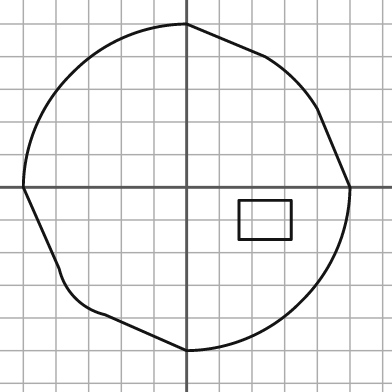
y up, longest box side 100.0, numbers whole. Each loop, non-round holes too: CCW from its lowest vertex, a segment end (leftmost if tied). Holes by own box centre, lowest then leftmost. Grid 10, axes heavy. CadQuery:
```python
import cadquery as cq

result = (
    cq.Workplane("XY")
    .moveTo(0.0, -50.0)
    .threePointArc((19.0, -46.0), (35.0, -35.0))
    .threePointArc((46.0, -19.0), (50.0, 0.0))
    .lineTo(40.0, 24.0)
    .threePointArc((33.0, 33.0), (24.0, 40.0))
    .lineTo(0.0, 50.0)
    .threePointArc((-19.0, 46.0), (-35.0, 35.0))
    .threePointArc((-46.0, 19.0), (-50.0, 0.0))
    .lineTo(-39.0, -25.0)
    .threePointArc((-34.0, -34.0), (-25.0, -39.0))
    .close()
    .moveTo(16.0, -16.0)
    .lineTo(32.0, -16.0)
    .lineTo(32.0, -4.0)
    .lineTo(16.0, -4.0)
    .close()
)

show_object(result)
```